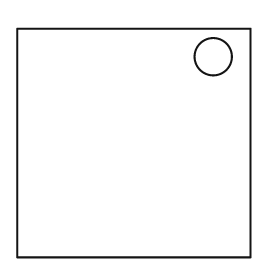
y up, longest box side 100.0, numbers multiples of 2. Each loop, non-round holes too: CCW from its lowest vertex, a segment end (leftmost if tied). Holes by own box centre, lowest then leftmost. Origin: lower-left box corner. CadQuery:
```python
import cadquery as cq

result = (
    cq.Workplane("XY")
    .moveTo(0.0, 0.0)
    .lineTo(100.0, 0.0)
    .lineTo(100.0, 98.0)
    .lineTo(0.0, 98.0)
    .close()
    .moveTo(84.0, 86.0)
    .circle(8.0)
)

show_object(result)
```